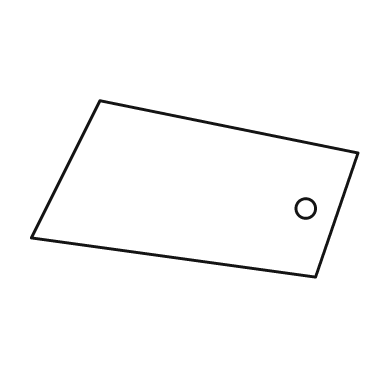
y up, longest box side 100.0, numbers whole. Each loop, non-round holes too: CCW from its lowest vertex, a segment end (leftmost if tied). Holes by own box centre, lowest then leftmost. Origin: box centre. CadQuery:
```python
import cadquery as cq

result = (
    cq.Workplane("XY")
    .moveTo(37.0, -27.0)
    .lineTo(50.0, 11.0)
    .lineTo(-29.0, 27.0)
    .lineTo(-50.0, -15.0)
    .close()
    .moveTo(34.0, -6.0)
    .circle(3.0)
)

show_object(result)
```